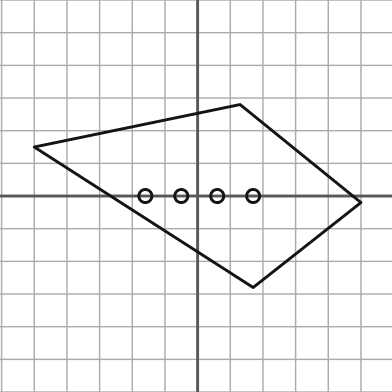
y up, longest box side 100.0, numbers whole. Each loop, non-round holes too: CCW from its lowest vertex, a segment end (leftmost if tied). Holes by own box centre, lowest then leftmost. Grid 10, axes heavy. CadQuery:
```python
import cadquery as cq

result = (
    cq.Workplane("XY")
    .moveTo(17.0, -28.0)
    .lineTo(50.0, -2.0)
    .lineTo(13.0, 28.0)
    .lineTo(-50.0, 15.0)
    .close()
    .moveTo(-16.0, 0.0)
    .circle(2.0)
    .moveTo(-5.0, 0.0)
    .circle(2.0)
    .moveTo(6.0, 0.0)
    .circle(2.0)
    .moveTo(17.0, 0.0)
    .circle(2.0)
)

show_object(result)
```